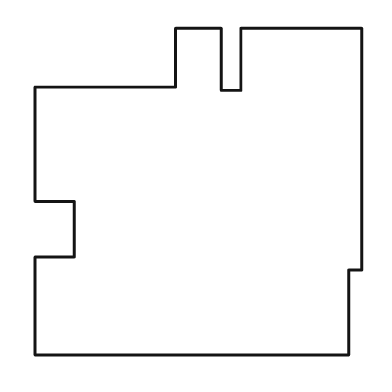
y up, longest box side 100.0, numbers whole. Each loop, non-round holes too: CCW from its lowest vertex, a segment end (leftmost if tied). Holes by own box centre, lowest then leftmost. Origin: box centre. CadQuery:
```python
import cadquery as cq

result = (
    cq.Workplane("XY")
    .moveTo(-50.0, -50.0)
    .lineTo(46.0, -50.0)
    .lineTo(46.0, -24.0)
    .lineTo(50.0, -24.0)
    .lineTo(50.0, 50.0)
    .lineTo(13.0, 50.0)
    .lineTo(13.0, 31.0)
    .lineTo(7.0, 31.0)
    .lineTo(7.0, 50.0)
    .lineTo(-7.0, 50.0)
    .lineTo(-7.0, 32.0)
    .lineTo(-50.0, 32.0)
    .lineTo(-50.0, -3.0)
    .lineTo(-38.0, -3.0)
    .lineTo(-38.0, -20.0)
    .lineTo(-50.0, -20.0)
    .close()
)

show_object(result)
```